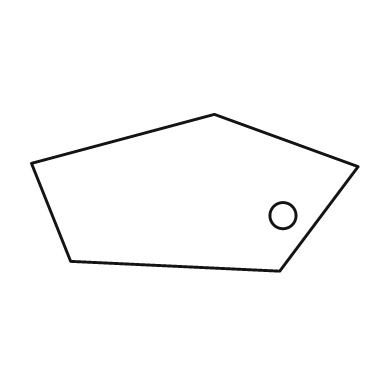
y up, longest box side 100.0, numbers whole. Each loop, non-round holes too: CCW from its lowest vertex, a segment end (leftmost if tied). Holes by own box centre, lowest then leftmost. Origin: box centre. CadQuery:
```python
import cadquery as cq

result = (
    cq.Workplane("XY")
    .moveTo(26.0, -24.0)
    .lineTo(50.0, 8.0)
    .lineTo(6.0, 24.0)
    .lineTo(-50.0, 9.0)
    .lineTo(-38.0, -21.0)
    .close()
    .moveTo(27.0, -7.0)
    .circle(4.0)
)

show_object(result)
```